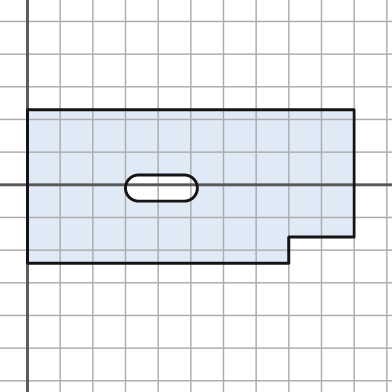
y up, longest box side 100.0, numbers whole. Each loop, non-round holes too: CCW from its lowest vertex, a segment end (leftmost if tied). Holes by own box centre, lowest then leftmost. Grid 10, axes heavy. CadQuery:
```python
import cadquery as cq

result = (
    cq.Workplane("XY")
    .moveTo(0.0, -24.0)
    .lineTo(80.0, -24.0)
    .lineTo(80.0, -16.0)
    .lineTo(100.0, -16.0)
    .lineTo(100.0, 23.0)
    .lineTo(0.0, 23.0)
    .close()
    .moveTo(34.0, -5.0)
    .lineTo(48.0, -5.0)
    .threePointArc((52.0, -1.0), (48.0, 3.0))
    .lineTo(34.0, 3.0)
    .threePointArc((30.0, -1.0), (34.0, -5.0))
    .close()
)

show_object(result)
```